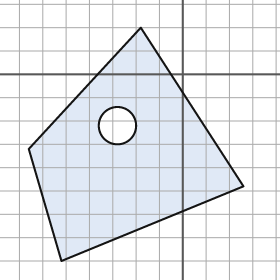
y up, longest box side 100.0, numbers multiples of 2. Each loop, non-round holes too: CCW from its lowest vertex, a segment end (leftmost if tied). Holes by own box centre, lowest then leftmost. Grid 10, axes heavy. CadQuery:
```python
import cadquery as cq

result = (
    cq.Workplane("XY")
    .moveTo(-52.0, -80.0)
    .lineTo(26.0, -48.0)
    .lineTo(-18.0, 20.0)
    .lineTo(-66.0, -32.0)
    .close()
    .moveTo(-28.0, -22.0)
    .circle(8.0)
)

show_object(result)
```